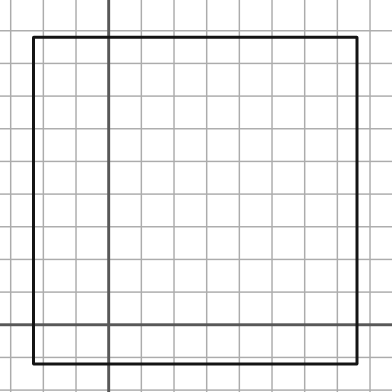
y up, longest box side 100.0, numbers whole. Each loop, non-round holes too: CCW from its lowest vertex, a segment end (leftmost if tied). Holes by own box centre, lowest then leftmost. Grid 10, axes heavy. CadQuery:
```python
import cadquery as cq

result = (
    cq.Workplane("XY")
    .moveTo(-23.0, -12.0)
    .lineTo(76.0, -12.0)
    .lineTo(76.0, 88.0)
    .lineTo(-23.0, 88.0)
    .close()
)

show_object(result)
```